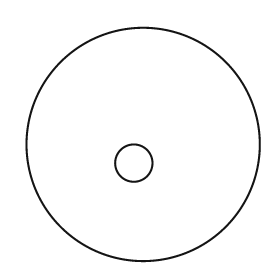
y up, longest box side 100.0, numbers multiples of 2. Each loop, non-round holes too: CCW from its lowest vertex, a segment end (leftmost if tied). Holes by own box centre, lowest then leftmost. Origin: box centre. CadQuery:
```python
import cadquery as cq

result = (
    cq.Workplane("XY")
    .moveTo(0.0, 0.0)
    .circle(50.0)
    .moveTo(-4.0, -8.0)
    .circle(8.0)
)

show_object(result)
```